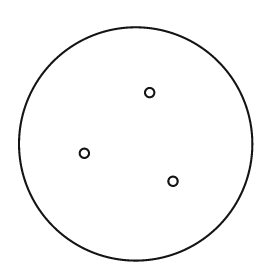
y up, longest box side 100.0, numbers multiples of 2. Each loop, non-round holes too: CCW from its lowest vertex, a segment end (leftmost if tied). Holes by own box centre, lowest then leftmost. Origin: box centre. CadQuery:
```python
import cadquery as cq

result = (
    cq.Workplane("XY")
    .moveTo(0.0, 0.0)
    .circle(50.0)
    .moveTo(16.0, -16.0)
    .circle(2.0)
    .moveTo(-22.0, -4.0)
    .circle(2.0)
    .moveTo(6.0, 22.0)
    .circle(2.0)
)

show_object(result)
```